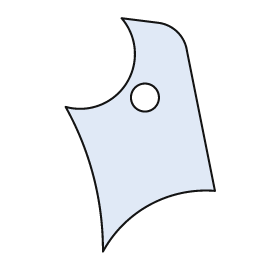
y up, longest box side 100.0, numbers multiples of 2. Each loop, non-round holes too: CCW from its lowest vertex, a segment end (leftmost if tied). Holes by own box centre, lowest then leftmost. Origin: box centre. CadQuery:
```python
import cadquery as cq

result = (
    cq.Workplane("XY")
    .moveTo(-16.0, -50.0)
    .threePointArc((4.0, -30.0), (32.0, -24.0))
    .lineTo(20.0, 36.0)
    .threePointArc((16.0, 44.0), (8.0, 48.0))
    .lineTo(-8.0, 50.0)
    .threePointArc((-6.0, 22.0), (-32.0, 12.0))
    .threePointArc((-20.0, -18.0), (-16.0, -50.0))
    .close()
    .moveTo(2.0, 16.0)
    .circle(6.0)
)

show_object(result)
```